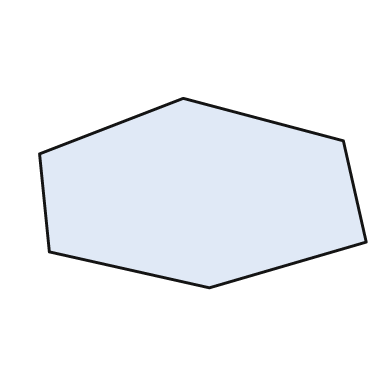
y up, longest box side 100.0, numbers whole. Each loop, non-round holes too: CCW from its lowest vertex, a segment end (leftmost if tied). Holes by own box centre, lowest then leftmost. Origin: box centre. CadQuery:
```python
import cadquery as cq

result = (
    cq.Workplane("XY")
    .moveTo(2.0, -29.0)
    .lineTo(50.0, -15.0)
    .lineTo(43.0, 16.0)
    .lineTo(-6.0, 29.0)
    .lineTo(-50.0, 12.0)
    .lineTo(-47.0, -18.0)
    .close()
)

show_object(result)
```